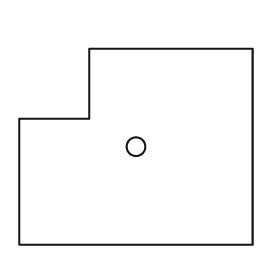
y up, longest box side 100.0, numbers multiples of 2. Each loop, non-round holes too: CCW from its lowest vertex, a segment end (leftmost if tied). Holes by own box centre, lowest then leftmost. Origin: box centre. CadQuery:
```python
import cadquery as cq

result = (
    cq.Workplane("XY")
    .moveTo(-50.0, -42.0)
    .lineTo(50.0, -42.0)
    .lineTo(50.0, 42.0)
    .lineTo(-20.0, 42.0)
    .lineTo(-20.0, 12.0)
    .lineTo(-50.0, 12.0)
    .close()
    .moveTo(0.0, 0.0)
    .circle(4.0)
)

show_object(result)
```